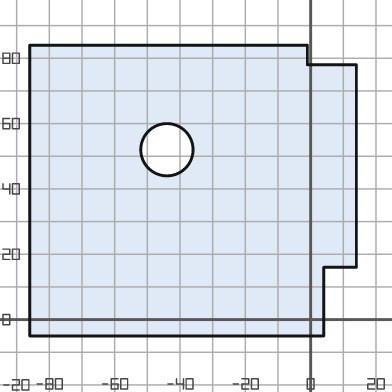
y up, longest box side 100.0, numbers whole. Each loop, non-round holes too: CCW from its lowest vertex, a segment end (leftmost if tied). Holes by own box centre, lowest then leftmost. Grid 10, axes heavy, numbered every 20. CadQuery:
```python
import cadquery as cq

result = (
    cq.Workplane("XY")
    .moveTo(-86.0, -5.0)
    .lineTo(4.0, -5.0)
    .lineTo(4.0, 16.0)
    .lineTo(14.0, 16.0)
    .lineTo(14.0, 78.0)
    .lineTo(-1.0, 78.0)
    .lineTo(-1.0, 84.0)
    .lineTo(-86.0, 84.0)
    .close()
    .moveTo(-44.0, 52.0)
    .circle(8.0)
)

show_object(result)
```